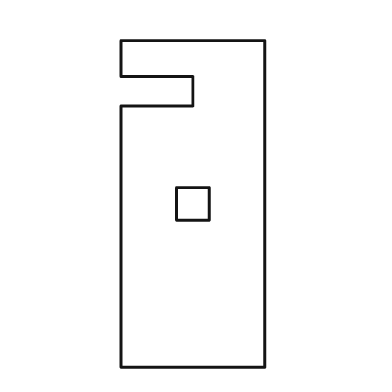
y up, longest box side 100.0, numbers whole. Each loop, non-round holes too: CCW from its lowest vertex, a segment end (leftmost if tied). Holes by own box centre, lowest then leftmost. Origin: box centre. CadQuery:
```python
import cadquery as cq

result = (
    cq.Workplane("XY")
    .moveTo(-22.0, -50.0)
    .lineTo(22.0, -50.0)
    .lineTo(22.0, 50.0)
    .lineTo(-22.0, 50.0)
    .lineTo(-22.0, 39.0)
    .lineTo(0.0, 39.0)
    .lineTo(0.0, 30.0)
    .lineTo(-22.0, 30.0)
    .close()
    .moveTo(-5.0, -5.0)
    .lineTo(5.0, -5.0)
    .lineTo(5.0, 5.0)
    .lineTo(-5.0, 5.0)
    .close()
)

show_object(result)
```